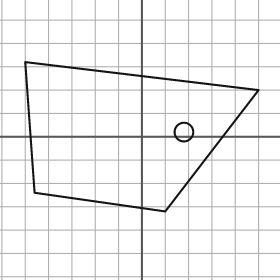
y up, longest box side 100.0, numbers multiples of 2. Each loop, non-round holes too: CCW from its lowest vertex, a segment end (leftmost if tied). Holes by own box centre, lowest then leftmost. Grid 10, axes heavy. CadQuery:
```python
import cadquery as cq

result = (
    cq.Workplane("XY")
    .moveTo(10.0, -32.0)
    .lineTo(50.0, 20.0)
    .lineTo(-50.0, 32.0)
    .lineTo(-46.0, -24.0)
    .close()
    .moveTo(18.0, 2.0)
    .circle(4.0)
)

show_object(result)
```